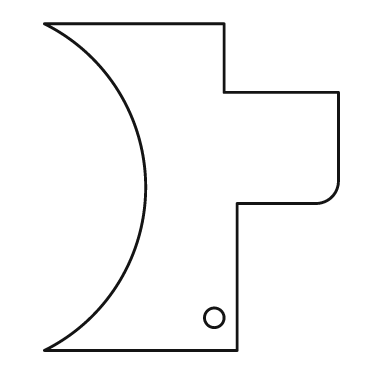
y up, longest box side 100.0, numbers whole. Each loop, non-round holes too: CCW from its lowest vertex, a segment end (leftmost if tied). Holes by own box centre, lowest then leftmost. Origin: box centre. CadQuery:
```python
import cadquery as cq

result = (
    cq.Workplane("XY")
    .moveTo(-45.0, -50.0)
    .lineTo(14.0, -50.0)
    .lineTo(14.0, -5.0)
    .lineTo(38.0, -5.0)
    .threePointArc((43.0, -3.0), (45.0, 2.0))
    .lineTo(45.0, 29.0)
    .lineTo(10.0, 29.0)
    .lineTo(10.0, 50.0)
    .lineTo(-45.0, 50.0)
    .threePointArc((-14.0, 0.0), (-45.0, -50.0))
    .close()
    .moveTo(7.0, -40.0)
    .circle(3.0)
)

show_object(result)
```